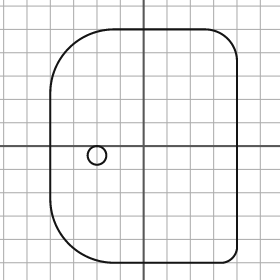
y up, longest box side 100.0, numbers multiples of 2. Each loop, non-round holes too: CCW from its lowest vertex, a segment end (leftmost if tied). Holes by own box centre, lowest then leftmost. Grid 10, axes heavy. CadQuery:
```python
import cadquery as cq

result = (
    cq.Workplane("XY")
    .moveTo(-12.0, -50.0)
    .lineTo(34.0, -50.0)
    .threePointArc((38.0, -48.0), (40.0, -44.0))
    .lineTo(40.0, 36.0)
    .threePointArc((36.0, 46.0), (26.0, 50.0))
    .lineTo(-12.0, 50.0)
    .threePointArc((-32.0, 42.0), (-40.0, 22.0))
    .lineTo(-40.0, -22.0)
    .threePointArc((-32.0, -42.0), (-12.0, -50.0))
    .close()
    .moveTo(-20.0, -4.0)
    .circle(4.0)
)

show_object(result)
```